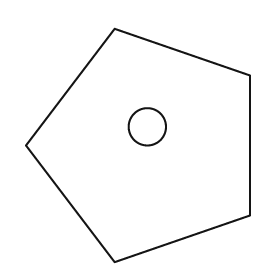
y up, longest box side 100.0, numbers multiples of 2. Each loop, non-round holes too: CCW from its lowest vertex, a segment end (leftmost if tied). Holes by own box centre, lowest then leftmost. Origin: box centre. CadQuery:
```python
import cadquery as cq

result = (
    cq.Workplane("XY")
    .moveTo(-10.0, -50.0)
    .lineTo(48.0, -30.0)
    .lineTo(48.0, 30.0)
    .lineTo(-10.0, 50.0)
    .lineTo(-48.0, 0.0)
    .close()
    .moveTo(4.0, 8.0)
    .circle(8.0)
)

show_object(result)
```